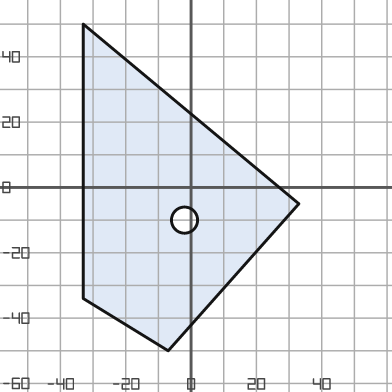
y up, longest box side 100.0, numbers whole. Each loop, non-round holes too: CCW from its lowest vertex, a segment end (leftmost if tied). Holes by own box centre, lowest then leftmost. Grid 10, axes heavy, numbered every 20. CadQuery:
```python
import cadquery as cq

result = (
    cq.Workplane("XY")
    .moveTo(-7.0, -50.0)
    .lineTo(33.0, -5.0)
    .lineTo(-33.0, 50.0)
    .lineTo(-33.0, -34.0)
    .close()
    .moveTo(-2.0, -10.0)
    .circle(4.0)
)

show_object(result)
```